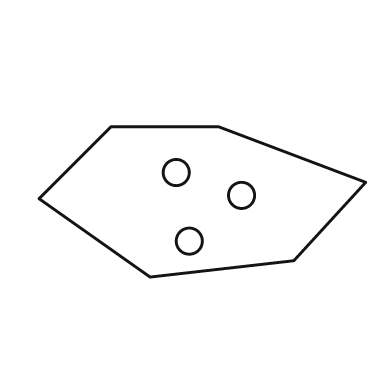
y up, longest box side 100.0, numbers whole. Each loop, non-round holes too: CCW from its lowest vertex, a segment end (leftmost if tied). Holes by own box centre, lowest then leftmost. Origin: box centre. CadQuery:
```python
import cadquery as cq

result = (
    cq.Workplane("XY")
    .moveTo(-16.0, -23.0)
    .lineTo(28.0, -18.0)
    .lineTo(50.0, 6.0)
    .lineTo(5.0, 23.0)
    .lineTo(-28.0, 23.0)
    .lineTo(-50.0, 1.0)
    .close()
    .moveTo(-4.0, -12.0)
    .circle(4.0)
    .moveTo(12.0, 2.0)
    .circle(4.0)
    .moveTo(-8.0, 9.0)
    .circle(4.0)
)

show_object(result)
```